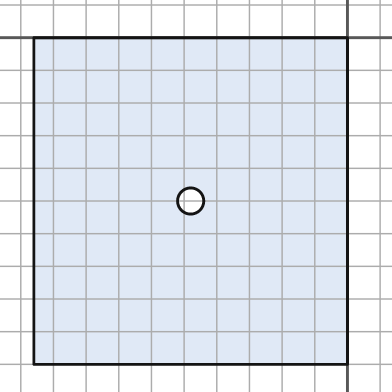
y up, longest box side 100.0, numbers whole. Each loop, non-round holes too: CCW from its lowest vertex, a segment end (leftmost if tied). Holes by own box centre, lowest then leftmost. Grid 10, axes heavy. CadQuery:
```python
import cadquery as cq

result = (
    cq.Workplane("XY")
    .moveTo(-96.0, -100.0)
    .lineTo(0.0, -100.0)
    .lineTo(0.0, 0.0)
    .lineTo(-96.0, 0.0)
    .close()
    .moveTo(-48.0, -50.0)
    .circle(4.0)
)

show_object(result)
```